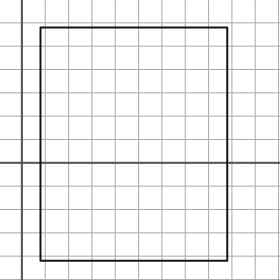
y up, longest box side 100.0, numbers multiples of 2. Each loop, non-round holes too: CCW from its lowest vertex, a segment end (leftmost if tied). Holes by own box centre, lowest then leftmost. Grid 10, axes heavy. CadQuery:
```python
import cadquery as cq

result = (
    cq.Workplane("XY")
    .moveTo(8.0, -42.0)
    .lineTo(88.0, -42.0)
    .lineTo(88.0, 58.0)
    .lineTo(8.0, 58.0)
    .close()
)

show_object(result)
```